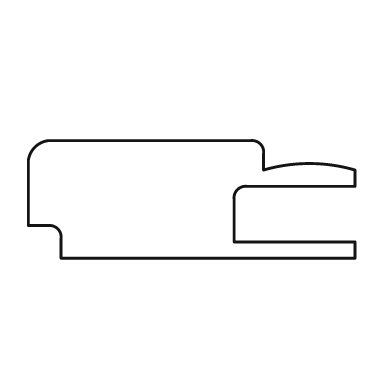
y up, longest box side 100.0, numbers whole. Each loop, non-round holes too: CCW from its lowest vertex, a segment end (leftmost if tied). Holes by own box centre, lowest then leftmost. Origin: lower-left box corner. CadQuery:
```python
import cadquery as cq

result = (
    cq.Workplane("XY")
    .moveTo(10.0, 0.0)
    .lineTo(100.0, 0.0)
    .lineTo(100.0, 5.0)
    .lineTo(63.0, 5.0)
    .lineTo(63.0, 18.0)
    .threePointArc((64.0, 21.0), (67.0, 22.0))
    .lineTo(100.0, 22.0)
    .lineTo(100.0, 27.0)
    .threePointArc((86.0, 29.0), (72.0, 27.0))
    .lineTo(72.0, 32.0)
    .threePointArc((71.0, 35.0), (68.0, 36.0))
    .lineTo(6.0, 36.0)
    .threePointArc((2.0, 34.0), (0.0, 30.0))
    .lineTo(0.0, 10.0)
    .lineTo(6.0, 10.0)
    .threePointArc((9.0, 9.0), (10.0, 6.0))
    .close()
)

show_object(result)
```